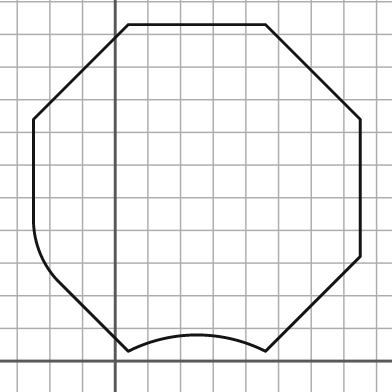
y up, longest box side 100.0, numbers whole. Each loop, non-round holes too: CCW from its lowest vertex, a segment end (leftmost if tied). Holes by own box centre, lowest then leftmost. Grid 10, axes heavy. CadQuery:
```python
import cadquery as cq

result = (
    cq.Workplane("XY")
    .moveTo(4.0, 3.0)
    .threePointArc((25.0, 8.0), (46.0, 3.0))
    .lineTo(75.0, 32.0)
    .lineTo(75.0, 74.0)
    .lineTo(46.0, 103.0)
    .lineTo(4.0, 103.0)
    .lineTo(-25.0, 74.0)
    .lineTo(-25.0, 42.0)
    .threePointArc((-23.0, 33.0), (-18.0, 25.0))
    .close()
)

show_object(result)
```